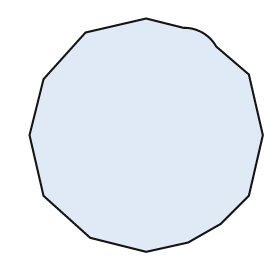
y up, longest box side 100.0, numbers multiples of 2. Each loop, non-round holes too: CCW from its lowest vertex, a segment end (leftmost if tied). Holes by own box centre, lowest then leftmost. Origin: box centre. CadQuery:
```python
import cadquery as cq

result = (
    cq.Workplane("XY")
    .moveTo(0.0, -50.0)
    .lineTo(18.0, -46.0)
    .lineTo(32.0, -38.0)
    .lineTo(44.0, -26.0)
    .lineTo(50.0, 0.0)
    .lineTo(44.0, 26.0)
    .lineTo(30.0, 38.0)
    .threePointArc((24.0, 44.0), (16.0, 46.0))
    .lineTo(0.0, 50.0)
    .lineTo(-26.0, 44.0)
    .lineTo(-44.0, 24.0)
    .lineTo(-50.0, 0.0)
    .lineTo(-44.0, -26.0)
    .lineTo(-24.0, -44.0)
    .close()
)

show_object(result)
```